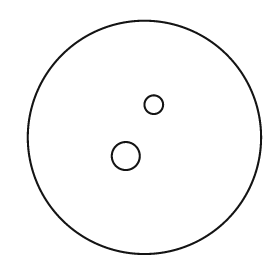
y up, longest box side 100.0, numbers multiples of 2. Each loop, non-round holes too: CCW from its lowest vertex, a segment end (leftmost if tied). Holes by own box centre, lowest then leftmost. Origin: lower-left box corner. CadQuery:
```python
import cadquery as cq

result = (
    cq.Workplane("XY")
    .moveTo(50.0, 50.0)
    .circle(50.0)
    .moveTo(42.0, 42.0)
    .circle(6.0)
    .moveTo(54.0, 64.0)
    .circle(4.0)
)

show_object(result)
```